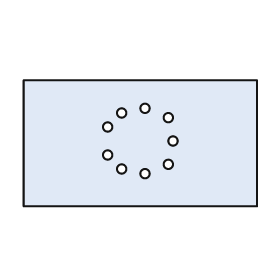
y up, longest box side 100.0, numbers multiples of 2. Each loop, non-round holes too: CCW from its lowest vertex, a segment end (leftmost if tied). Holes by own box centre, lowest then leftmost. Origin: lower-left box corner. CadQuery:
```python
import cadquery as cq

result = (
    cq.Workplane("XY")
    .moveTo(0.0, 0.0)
    .lineTo(100.0, 0.0)
    .lineTo(100.0, 54.0)
    .lineTo(0.0, 54.0)
    .close()
    .moveTo(52.0, 14.0)
    .circle(2.0)
    .moveTo(42.0, 16.0)
    .circle(2.0)
    .moveTo(62.0, 18.0)
    .circle(2.0)
    .moveTo(36.0, 22.0)
    .circle(2.0)
    .moveTo(64.0, 28.0)
    .circle(2.0)
    .moveTo(36.0, 34.0)
    .circle(2.0)
    .moveTo(62.0, 38.0)
    .circle(2.0)
    .moveTo(42.0, 40.0)
    .circle(2.0)
    .moveTo(52.0, 42.0)
    .circle(2.0)
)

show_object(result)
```